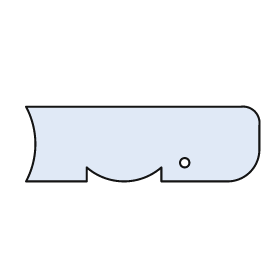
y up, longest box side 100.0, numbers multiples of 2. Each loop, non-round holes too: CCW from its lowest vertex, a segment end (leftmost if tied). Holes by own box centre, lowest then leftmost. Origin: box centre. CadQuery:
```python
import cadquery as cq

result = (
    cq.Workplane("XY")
    .moveTo(-50.0, -16.0)
    .lineTo(-24.0, -16.0)
    .lineTo(-24.0, -10.0)
    .threePointArc((-8.0, -16.0), (8.0, -10.0))
    .lineTo(8.0, -16.0)
    .lineTo(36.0, -16.0)
    .threePointArc((46.0, -12.0), (50.0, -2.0))
    .lineTo(50.0, 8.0)
    .threePointArc((48.0, 14.0), (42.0, 16.0))
    .lineTo(-50.0, 16.0)
    .threePointArc((-46.0, 0.0), (-50.0, -16.0))
    .close()
    .moveTo(18.0, -8.0)
    .circle(2.0)
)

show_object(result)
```